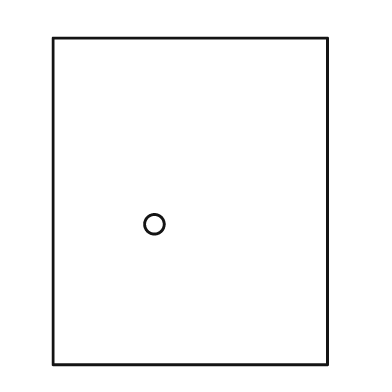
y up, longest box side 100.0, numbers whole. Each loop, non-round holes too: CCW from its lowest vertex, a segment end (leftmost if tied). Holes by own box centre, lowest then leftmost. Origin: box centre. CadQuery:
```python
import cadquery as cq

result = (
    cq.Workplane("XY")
    .moveTo(-42.0, -50.0)
    .lineTo(42.0, -50.0)
    .lineTo(42.0, 50.0)
    .lineTo(-42.0, 50.0)
    .close()
    .moveTo(-11.0, -7.0)
    .circle(3.0)
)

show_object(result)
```